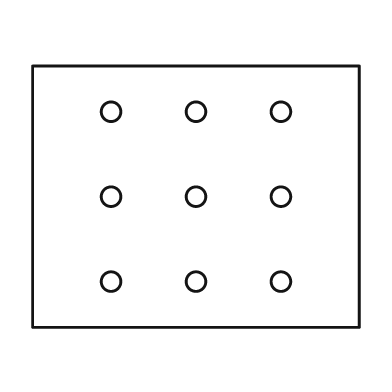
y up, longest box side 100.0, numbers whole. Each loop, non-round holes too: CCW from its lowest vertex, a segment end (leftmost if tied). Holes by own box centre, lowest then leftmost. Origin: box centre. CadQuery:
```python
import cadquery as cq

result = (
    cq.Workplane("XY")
    .moveTo(-50.0, -40.0)
    .lineTo(50.0, -40.0)
    .lineTo(50.0, 40.0)
    .lineTo(-50.0, 40.0)
    .close()
    .moveTo(-26.0, -26.0)
    .circle(3.0)
    .moveTo(0.0, -26.0)
    .circle(3.0)
    .moveTo(26.0, -26.0)
    .circle(3.0)
    .moveTo(-26.0, 0.0)
    .circle(3.0)
    .moveTo(0.0, 0.0)
    .circle(3.0)
    .moveTo(26.0, 0.0)
    .circle(3.0)
    .moveTo(-26.0, 26.0)
    .circle(3.0)
    .moveTo(0.0, 26.0)
    .circle(3.0)
    .moveTo(26.0, 26.0)
    .circle(3.0)
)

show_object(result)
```